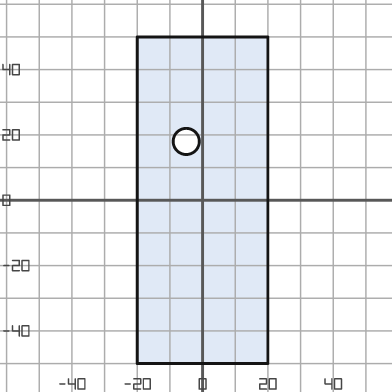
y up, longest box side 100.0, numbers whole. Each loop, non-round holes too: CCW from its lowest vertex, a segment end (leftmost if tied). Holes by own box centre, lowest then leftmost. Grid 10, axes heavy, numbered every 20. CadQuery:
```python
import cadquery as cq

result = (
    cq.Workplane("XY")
    .moveTo(-20.0, -50.0)
    .lineTo(20.0, -50.0)
    .lineTo(20.0, 50.0)
    .lineTo(-20.0, 50.0)
    .close()
    .moveTo(-5.0, 18.0)
    .circle(4.0)
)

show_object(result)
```